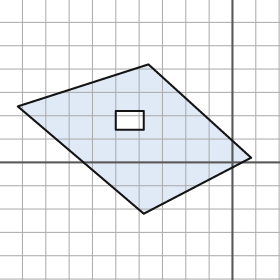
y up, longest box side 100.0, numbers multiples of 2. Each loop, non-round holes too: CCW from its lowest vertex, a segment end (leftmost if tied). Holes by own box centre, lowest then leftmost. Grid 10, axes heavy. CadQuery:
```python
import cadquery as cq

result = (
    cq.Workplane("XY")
    .moveTo(-38.0, -22.0)
    .lineTo(8.0, 2.0)
    .lineTo(-36.0, 42.0)
    .lineTo(-92.0, 24.0)
    .close()
    .moveTo(-50.0, 14.0)
    .lineTo(-38.0, 14.0)
    .lineTo(-38.0, 22.0)
    .lineTo(-50.0, 22.0)
    .close()
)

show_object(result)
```